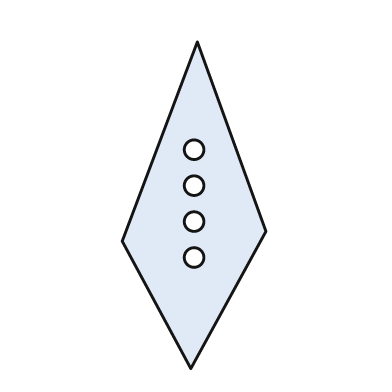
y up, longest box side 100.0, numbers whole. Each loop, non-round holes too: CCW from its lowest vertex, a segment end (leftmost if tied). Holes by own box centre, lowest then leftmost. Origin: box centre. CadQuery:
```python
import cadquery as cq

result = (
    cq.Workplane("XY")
    .moveTo(-1.0, -50.0)
    .lineTo(22.0, -8.0)
    .lineTo(1.0, 50.0)
    .lineTo(-22.0, -11.0)
    .close()
    .moveTo(0.0, -16.0)
    .circle(3.0)
    .moveTo(0.0, -5.0)
    .circle(3.0)
    .moveTo(0.0, 6.0)
    .circle(3.0)
    .moveTo(0.0, 17.0)
    .circle(3.0)
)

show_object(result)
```